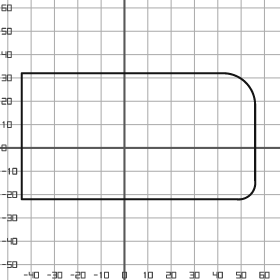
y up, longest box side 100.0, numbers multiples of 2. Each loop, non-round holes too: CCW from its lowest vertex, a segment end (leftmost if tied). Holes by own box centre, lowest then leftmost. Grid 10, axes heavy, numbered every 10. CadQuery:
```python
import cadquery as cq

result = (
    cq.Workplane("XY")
    .moveTo(-44.0, -22.0)
    .lineTo(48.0, -22.0)
    .threePointArc((54.0, -20.0), (56.0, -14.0))
    .lineTo(56.0, 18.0)
    .threePointArc((52.0, 28.0), (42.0, 32.0))
    .lineTo(-44.0, 32.0)
    .close()
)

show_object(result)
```